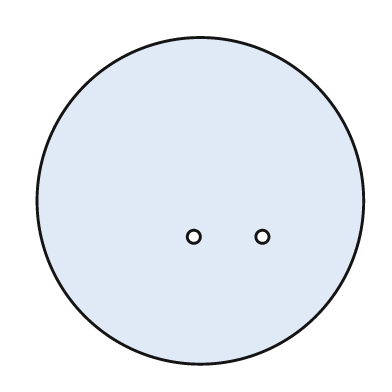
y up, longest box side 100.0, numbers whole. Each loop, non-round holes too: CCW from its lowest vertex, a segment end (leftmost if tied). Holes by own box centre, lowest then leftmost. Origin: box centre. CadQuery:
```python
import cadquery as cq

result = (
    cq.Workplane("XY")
    .moveTo(0.0, 0.0)
    .circle(50.0)
    .moveTo(-2.0, -11.0)
    .circle(2.0)
    .moveTo(19.0, -11.0)
    .circle(2.0)
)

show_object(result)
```